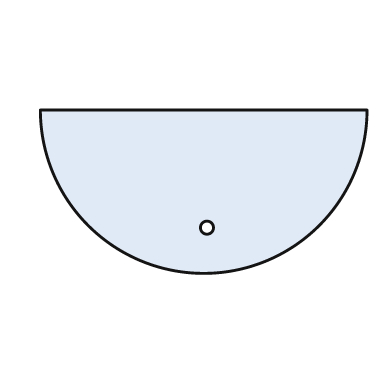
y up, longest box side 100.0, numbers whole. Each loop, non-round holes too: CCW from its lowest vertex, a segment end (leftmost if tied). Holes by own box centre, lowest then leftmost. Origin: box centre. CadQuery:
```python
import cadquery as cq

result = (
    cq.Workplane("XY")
    .moveTo(-50.0, 25.0)
    .threePointArc((0.0, -25.0), (50.0, 25.0))
    .close()
    .moveTo(1.0, -11.0)
    .circle(2.0)
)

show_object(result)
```